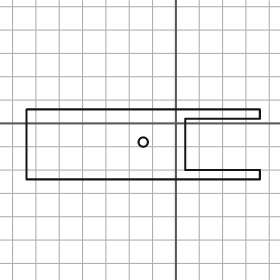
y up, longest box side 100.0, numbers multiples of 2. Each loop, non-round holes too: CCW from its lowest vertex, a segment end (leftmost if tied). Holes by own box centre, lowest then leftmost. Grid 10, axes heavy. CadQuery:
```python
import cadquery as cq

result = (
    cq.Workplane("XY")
    .moveTo(-64.0, -24.0)
    .lineTo(36.0, -24.0)
    .lineTo(36.0, -20.0)
    .lineTo(4.0, -20.0)
    .lineTo(4.0, 2.0)
    .lineTo(36.0, 2.0)
    .lineTo(36.0, 6.0)
    .lineTo(-64.0, 6.0)
    .close()
    .moveTo(-14.0, -8.0)
    .circle(2.0)
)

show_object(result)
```